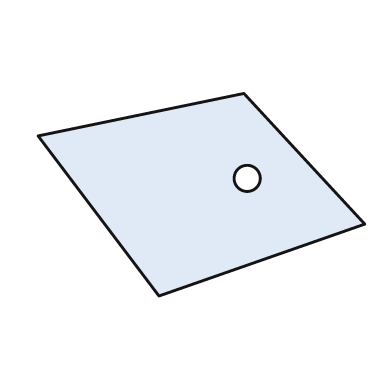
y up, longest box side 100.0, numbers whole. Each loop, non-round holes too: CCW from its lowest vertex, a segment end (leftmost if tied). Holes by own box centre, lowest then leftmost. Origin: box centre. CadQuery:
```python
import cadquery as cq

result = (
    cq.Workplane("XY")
    .moveTo(-13.0, -31.0)
    .lineTo(50.0, -9.0)
    .lineTo(13.0, 31.0)
    .lineTo(-50.0, 18.0)
    .close()
    .moveTo(14.0, 5.0)
    .circle(4.0)
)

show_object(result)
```